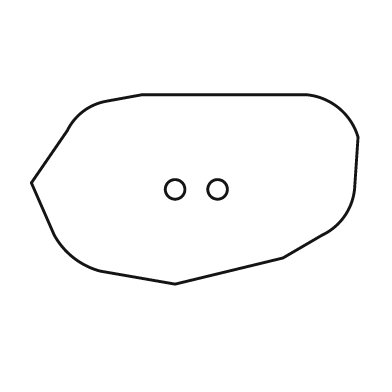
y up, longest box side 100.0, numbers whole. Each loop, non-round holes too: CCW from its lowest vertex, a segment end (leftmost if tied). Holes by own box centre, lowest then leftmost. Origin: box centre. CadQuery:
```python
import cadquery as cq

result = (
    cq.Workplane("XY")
    .moveTo(-6.0, -29.0)
    .lineTo(27.0, -21.0)
    .lineTo(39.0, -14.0)
    .threePointArc((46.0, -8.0), (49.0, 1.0))
    .lineTo(50.0, 16.0)
    .threePointArc((44.0, 25.0), (34.0, 29.0))
    .lineTo(-16.0, 29.0)
    .lineTo(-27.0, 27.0)
    .threePointArc((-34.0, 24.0), (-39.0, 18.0))
    .lineTo(-50.0, 2.0)
    .lineTo(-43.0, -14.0)
    .threePointArc((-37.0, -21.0), (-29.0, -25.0))
    .close()
    .moveTo(-6.0, 0.0)
    .circle(3.0)
    .moveTo(7.0, 0.0)
    .circle(3.0)
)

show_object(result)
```